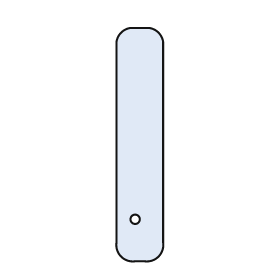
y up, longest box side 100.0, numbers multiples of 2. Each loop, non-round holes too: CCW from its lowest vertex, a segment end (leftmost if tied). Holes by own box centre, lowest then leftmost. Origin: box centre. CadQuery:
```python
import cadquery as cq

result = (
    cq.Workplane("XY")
    .moveTo(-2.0, -50.0)
    .lineTo(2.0, -50.0)
    .threePointArc((8.0, -48.0), (10.0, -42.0))
    .lineTo(10.0, 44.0)
    .threePointArc((8.0, 48.0), (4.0, 50.0))
    .lineTo(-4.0, 50.0)
    .threePointArc((-8.0, 48.0), (-10.0, 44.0))
    .lineTo(-10.0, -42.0)
    .threePointArc((-8.0, -48.0), (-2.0, -50.0))
    .close()
    .moveTo(-2.0, -32.0)
    .circle(2.0)
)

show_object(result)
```